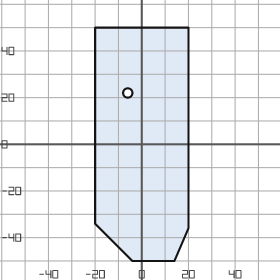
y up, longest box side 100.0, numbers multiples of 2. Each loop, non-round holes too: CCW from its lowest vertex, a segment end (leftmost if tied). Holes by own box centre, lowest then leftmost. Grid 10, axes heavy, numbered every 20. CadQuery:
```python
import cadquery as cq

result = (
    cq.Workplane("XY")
    .moveTo(-4.0, -50.0)
    .lineTo(14.0, -50.0)
    .lineTo(20.0, -36.0)
    .lineTo(20.0, 50.0)
    .lineTo(-20.0, 50.0)
    .lineTo(-20.0, -34.0)
    .close()
    .moveTo(-6.0, 22.0)
    .circle(2.0)
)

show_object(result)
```